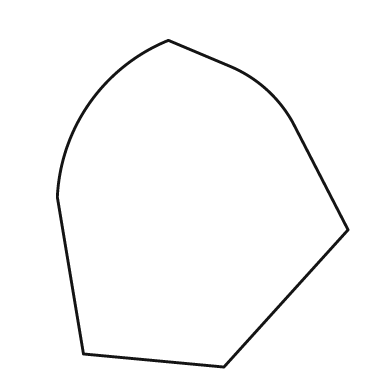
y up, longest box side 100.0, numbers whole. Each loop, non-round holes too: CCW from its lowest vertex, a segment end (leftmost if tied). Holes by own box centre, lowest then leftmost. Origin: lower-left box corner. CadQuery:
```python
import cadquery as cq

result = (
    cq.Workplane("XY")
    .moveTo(51.0, 0.0)
    .lineTo(89.0, 42.0)
    .lineTo(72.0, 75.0)
    .threePointArc((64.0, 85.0), (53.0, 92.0))
    .lineTo(34.0, 100.0)
    .threePointArc((10.0, 81.0), (0.0, 52.0))
    .lineTo(8.0, 4.0)
    .close()
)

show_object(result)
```